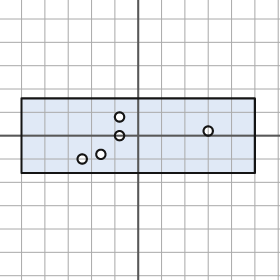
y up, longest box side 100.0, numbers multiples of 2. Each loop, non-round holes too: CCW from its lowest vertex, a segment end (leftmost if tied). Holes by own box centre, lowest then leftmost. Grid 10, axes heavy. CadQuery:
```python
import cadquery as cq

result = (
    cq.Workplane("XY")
    .moveTo(-50.0, -16.0)
    .lineTo(50.0, -16.0)
    .lineTo(50.0, 16.0)
    .lineTo(-50.0, 16.0)
    .close()
    .moveTo(-24.0, -10.0)
    .circle(2.0)
    .moveTo(-16.0, -8.0)
    .circle(2.0)
    .moveTo(-8.0, 0.0)
    .circle(2.0)
    .moveTo(30.0, 2.0)
    .circle(2.0)
    .moveTo(-8.0, 8.0)
    .circle(2.0)
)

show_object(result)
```